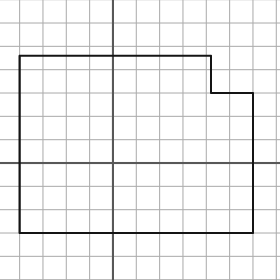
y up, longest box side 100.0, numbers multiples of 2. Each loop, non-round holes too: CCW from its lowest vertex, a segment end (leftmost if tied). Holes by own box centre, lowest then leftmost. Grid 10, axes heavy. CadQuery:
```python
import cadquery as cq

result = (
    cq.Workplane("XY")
    .moveTo(-40.0, -30.0)
    .lineTo(60.0, -30.0)
    .lineTo(60.0, 30.0)
    .lineTo(42.0, 30.0)
    .lineTo(42.0, 46.0)
    .lineTo(-40.0, 46.0)
    .close()
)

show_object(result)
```